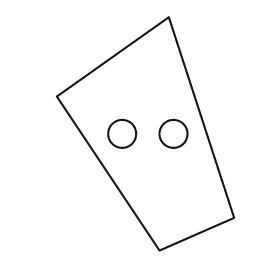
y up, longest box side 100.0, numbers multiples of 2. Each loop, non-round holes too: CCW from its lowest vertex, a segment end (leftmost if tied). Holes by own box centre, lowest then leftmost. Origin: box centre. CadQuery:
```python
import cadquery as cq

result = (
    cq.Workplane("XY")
    .moveTo(6.0, -50.0)
    .lineTo(38.0, -36.0)
    .lineTo(10.0, 50.0)
    .lineTo(-38.0, 16.0)
    .close()
    .moveTo(-10.0, 0.0)
    .circle(6.0)
    .moveTo(12.0, 0.0)
    .circle(6.0)
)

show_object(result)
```